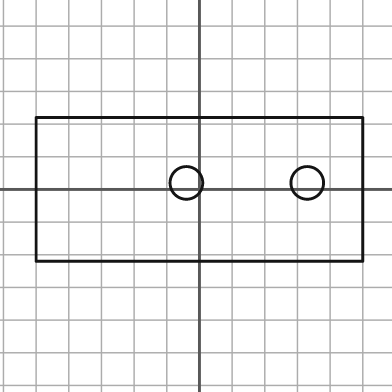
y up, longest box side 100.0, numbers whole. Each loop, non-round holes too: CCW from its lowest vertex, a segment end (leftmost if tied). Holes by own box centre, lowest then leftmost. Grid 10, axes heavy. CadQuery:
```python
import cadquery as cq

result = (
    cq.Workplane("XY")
    .moveTo(-50.0, -22.0)
    .lineTo(50.0, -22.0)
    .lineTo(50.0, 22.0)
    .lineTo(-50.0, 22.0)
    .close()
    .moveTo(-4.0, 2.0)
    .circle(5.0)
    .moveTo(33.0, 2.0)
    .circle(5.0)
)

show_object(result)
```